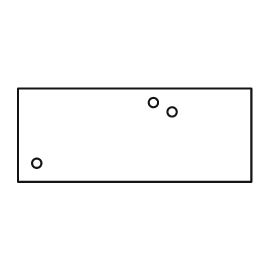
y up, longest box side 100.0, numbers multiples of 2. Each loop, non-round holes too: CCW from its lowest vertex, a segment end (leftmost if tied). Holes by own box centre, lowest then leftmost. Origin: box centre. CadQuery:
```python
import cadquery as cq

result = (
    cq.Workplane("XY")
    .moveTo(-50.0, -20.0)
    .lineTo(50.0, -20.0)
    .lineTo(50.0, 20.0)
    .lineTo(-50.0, 20.0)
    .close()
    .moveTo(-42.0, -12.0)
    .circle(2.0)
    .moveTo(16.0, 10.0)
    .circle(2.0)
    .moveTo(8.0, 14.0)
    .circle(2.0)
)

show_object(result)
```